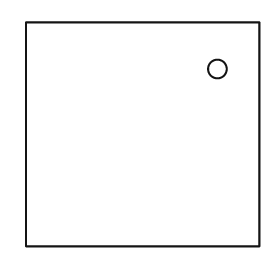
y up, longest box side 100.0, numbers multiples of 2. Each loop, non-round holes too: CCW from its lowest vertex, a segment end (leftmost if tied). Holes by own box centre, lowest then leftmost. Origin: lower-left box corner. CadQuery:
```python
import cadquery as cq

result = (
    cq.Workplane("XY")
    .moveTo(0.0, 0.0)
    .lineTo(100.0, 0.0)
    .lineTo(100.0, 96.0)
    .lineTo(0.0, 96.0)
    .close()
    .moveTo(82.0, 76.0)
    .circle(4.0)
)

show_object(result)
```